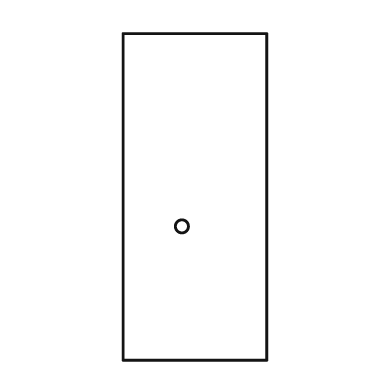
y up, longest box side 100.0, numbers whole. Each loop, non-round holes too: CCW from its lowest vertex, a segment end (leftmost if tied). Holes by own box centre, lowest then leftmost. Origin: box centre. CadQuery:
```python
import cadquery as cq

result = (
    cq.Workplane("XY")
    .moveTo(-22.0, -50.0)
    .lineTo(22.0, -50.0)
    .lineTo(22.0, 50.0)
    .lineTo(-22.0, 50.0)
    .close()
    .moveTo(-4.0, -9.0)
    .circle(2.0)
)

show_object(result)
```